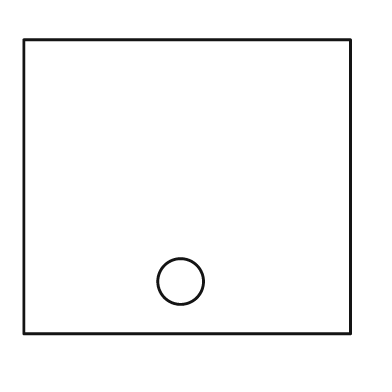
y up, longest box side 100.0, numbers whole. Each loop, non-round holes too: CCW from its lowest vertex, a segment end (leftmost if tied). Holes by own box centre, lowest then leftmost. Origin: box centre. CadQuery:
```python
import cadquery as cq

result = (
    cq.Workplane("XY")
    .moveTo(-50.0, -45.0)
    .lineTo(50.0, -45.0)
    .lineTo(50.0, 45.0)
    .lineTo(-50.0, 45.0)
    .close()
    .moveTo(-2.0, -29.0)
    .circle(7.0)
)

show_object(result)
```